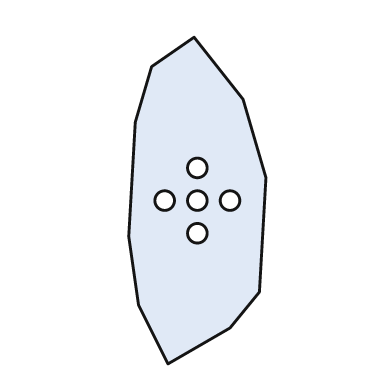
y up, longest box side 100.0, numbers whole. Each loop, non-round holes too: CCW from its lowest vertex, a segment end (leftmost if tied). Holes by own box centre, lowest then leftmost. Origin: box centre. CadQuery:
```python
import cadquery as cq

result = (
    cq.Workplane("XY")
    .moveTo(-9.0, -50.0)
    .lineTo(10.0, -39.0)
    .lineTo(19.0, -28.0)
    .lineTo(21.0, 7.0)
    .lineTo(14.0, 31.0)
    .lineTo(-1.0, 50.0)
    .lineTo(-14.0, 41.0)
    .lineTo(-19.0, 24.0)
    .lineTo(-21.0, -11.0)
    .lineTo(-18.0, -32.0)
    .close()
    .moveTo(0.0, -10.0)
    .circle(3.0)
    .moveTo(-10.0, 0.0)
    .circle(3.0)
    .moveTo(0.0, 0.0)
    .circle(3.0)
    .moveTo(10.0, 0.0)
    .circle(3.0)
    .moveTo(0.0, 10.0)
    .circle(3.0)
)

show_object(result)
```